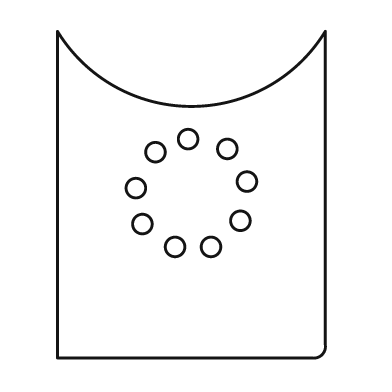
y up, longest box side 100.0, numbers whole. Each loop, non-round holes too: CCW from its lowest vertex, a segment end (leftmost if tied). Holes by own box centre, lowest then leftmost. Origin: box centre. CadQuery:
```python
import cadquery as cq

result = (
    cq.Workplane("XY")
    .moveTo(-41.0, -50.0)
    .lineTo(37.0, -50.0)
    .threePointArc((40.0, -49.0), (41.0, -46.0))
    .lineTo(41.0, 50.0)
    .threePointArc((0.0, 27.0), (-41.0, 50.0))
    .close()
    .moveTo(-5.0, -16.0)
    .circle(3.0)
    .moveTo(6.0, -16.0)
    .circle(3.0)
    .moveTo(-15.0, -9.0)
    .circle(3.0)
    .moveTo(15.0, -8.0)
    .circle(3.0)
    .moveTo(-17.0, 2.0)
    .circle(3.0)
    .moveTo(17.0, 4.0)
    .circle(3.0)
    .moveTo(-11.0, 13.0)
    .circle(3.0)
    .moveTo(11.0, 14.0)
    .circle(3.0)
    .moveTo(-1.0, 17.0)
    .circle(3.0)
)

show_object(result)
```